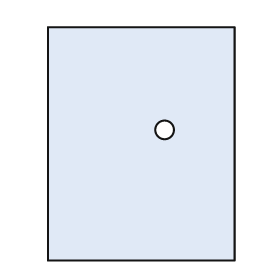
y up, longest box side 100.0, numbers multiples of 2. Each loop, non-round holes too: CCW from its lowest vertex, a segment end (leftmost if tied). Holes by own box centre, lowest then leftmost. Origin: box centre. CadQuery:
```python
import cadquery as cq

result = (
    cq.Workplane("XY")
    .moveTo(-40.0, -50.0)
    .lineTo(40.0, -50.0)
    .lineTo(40.0, 50.0)
    .lineTo(-40.0, 50.0)
    .close()
    .moveTo(10.0, 6.0)
    .circle(4.0)
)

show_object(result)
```